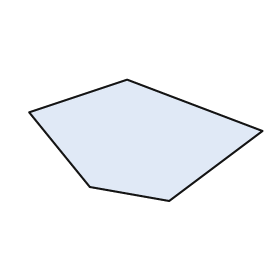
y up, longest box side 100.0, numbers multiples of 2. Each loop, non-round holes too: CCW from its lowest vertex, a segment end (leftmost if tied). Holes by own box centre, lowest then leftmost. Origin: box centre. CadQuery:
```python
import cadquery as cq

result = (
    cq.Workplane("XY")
    .moveTo(10.0, -26.0)
    .lineTo(50.0, 4.0)
    .lineTo(-8.0, 26.0)
    .lineTo(-50.0, 12.0)
    .lineTo(-24.0, -20.0)
    .close()
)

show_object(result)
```